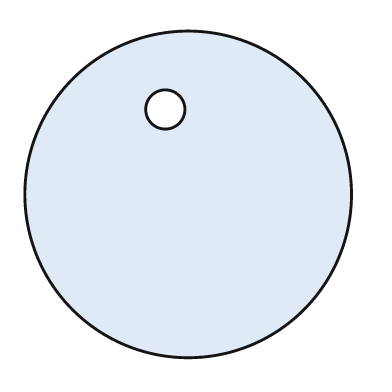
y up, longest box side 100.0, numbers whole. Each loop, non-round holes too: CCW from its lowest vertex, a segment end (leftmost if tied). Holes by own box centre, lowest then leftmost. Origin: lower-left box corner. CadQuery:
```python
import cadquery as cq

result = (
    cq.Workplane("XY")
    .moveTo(50.0, 50.0)
    .circle(50.0)
    .moveTo(43.0, 76.0)
    .circle(6.0)
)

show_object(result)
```